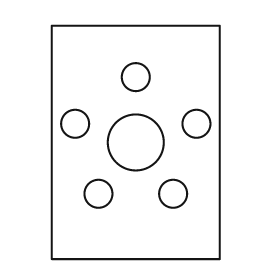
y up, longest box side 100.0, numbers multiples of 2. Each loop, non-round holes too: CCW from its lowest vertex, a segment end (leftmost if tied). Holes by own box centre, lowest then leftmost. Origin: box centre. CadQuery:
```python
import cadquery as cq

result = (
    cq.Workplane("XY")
    .moveTo(-36.0, -50.0)
    .lineTo(36.0, -50.0)
    .lineTo(36.0, 50.0)
    .lineTo(-36.0, 50.0)
    .close()
    .moveTo(-16.0, -22.0)
    .circle(6.0)
    .moveTo(16.0, -22.0)
    .circle(6.0)
    .moveTo(0.0, 0.0)
    .circle(12.0)
    .moveTo(-26.0, 8.0)
    .circle(6.0)
    .moveTo(26.0, 8.0)
    .circle(6.0)
    .moveTo(0.0, 28.0)
    .circle(6.0)
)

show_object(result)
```